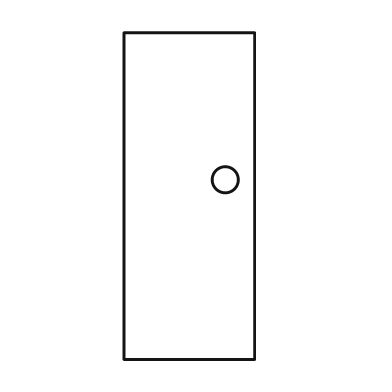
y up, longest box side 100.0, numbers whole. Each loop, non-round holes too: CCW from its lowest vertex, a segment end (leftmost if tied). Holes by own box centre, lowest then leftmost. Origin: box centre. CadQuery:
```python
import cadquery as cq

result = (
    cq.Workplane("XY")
    .moveTo(-20.0, -50.0)
    .lineTo(20.0, -50.0)
    .lineTo(20.0, 50.0)
    .lineTo(-20.0, 50.0)
    .close()
    .moveTo(11.0, 5.0)
    .circle(4.0)
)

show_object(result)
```